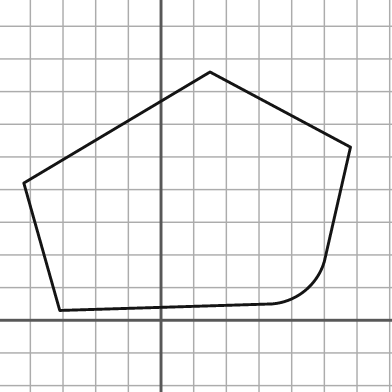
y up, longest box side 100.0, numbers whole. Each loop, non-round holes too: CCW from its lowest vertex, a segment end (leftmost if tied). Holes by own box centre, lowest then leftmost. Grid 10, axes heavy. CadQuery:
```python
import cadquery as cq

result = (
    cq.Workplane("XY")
    .moveTo(-31.0, 3.0)
    .lineTo(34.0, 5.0)
    .threePointArc((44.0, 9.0), (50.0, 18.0))
    .lineTo(58.0, 53.0)
    .lineTo(15.0, 76.0)
    .lineTo(-42.0, 42.0)
    .close()
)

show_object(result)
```